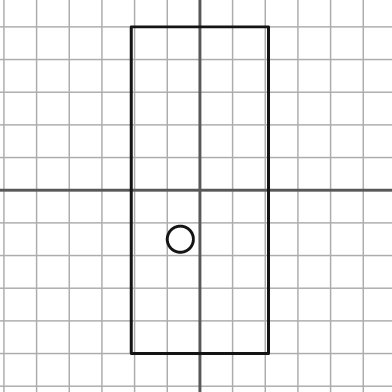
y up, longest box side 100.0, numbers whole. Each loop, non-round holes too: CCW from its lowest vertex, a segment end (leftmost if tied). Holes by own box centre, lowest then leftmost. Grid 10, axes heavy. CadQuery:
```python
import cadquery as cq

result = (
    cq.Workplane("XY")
    .moveTo(-21.0, -50.0)
    .lineTo(21.0, -50.0)
    .lineTo(21.0, 50.0)
    .lineTo(-21.0, 50.0)
    .close()
    .moveTo(-6.0, -15.0)
    .circle(4.0)
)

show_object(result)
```